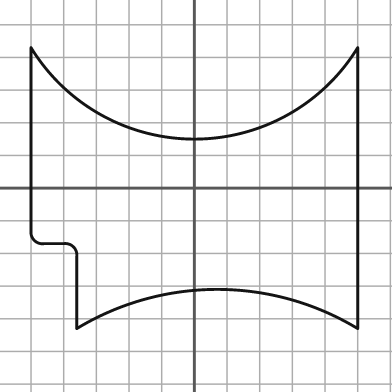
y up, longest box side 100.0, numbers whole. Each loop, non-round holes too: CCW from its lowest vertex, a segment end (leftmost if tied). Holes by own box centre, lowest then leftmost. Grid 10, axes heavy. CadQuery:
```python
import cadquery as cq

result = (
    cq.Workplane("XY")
    .moveTo(-36.0, -43.0)
    .threePointArc((7.0, -31.0), (50.0, -43.0))
    .lineTo(50.0, 43.0)
    .threePointArc((0.0, 15.0), (-50.0, 43.0))
    .lineTo(-50.0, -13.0)
    .threePointArc((-49.0, -16.0), (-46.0, -17.0))
    .lineTo(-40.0, -17.0)
    .threePointArc((-37.0, -18.0), (-36.0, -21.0))
    .close()
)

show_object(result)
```